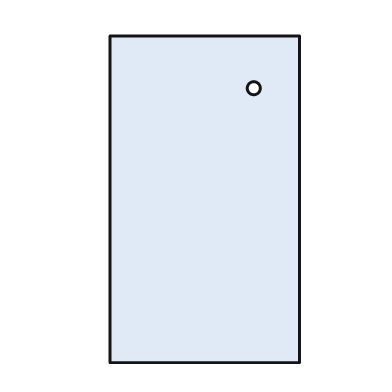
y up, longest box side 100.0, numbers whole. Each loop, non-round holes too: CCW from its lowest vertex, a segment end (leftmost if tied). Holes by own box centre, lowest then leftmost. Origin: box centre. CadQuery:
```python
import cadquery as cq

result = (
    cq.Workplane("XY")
    .moveTo(-29.0, -50.0)
    .lineTo(29.0, -50.0)
    .lineTo(29.0, 50.0)
    .lineTo(-29.0, 50.0)
    .close()
    .moveTo(15.0, 34.0)
    .circle(2.0)
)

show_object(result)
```